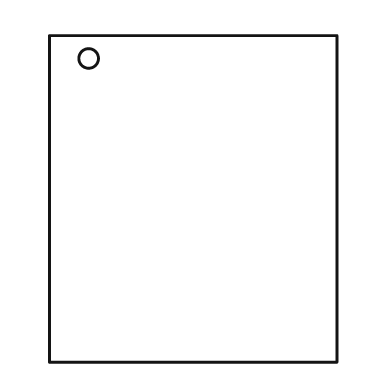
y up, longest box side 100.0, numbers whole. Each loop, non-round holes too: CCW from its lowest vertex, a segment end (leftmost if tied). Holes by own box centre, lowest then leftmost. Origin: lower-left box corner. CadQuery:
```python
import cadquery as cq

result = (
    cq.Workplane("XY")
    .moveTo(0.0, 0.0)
    .lineTo(88.0, 0.0)
    .lineTo(88.0, 100.0)
    .lineTo(0.0, 100.0)
    .close()
    .moveTo(12.0, 93.0)
    .circle(3.0)
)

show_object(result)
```